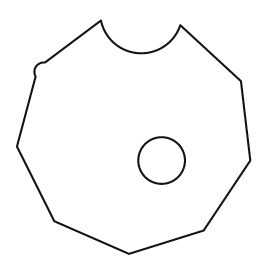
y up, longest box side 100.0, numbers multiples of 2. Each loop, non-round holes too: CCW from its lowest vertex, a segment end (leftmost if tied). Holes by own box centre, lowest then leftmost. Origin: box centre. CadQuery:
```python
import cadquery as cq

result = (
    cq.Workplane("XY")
    .moveTo(-2.0, -50.0)
    .lineTo(30.0, -40.0)
    .lineTo(50.0, -10.0)
    .lineTo(46.0, 24.0)
    .lineTo(20.0, 48.0)
    .threePointArc((2.0, 36.0), (-14.0, 50.0))
    .lineTo(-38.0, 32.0)
    .threePointArc((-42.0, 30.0), (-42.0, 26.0))
    .lineTo(-50.0, -4.0)
    .lineTo(-34.0, -36.0)
    .close()
    .moveTo(12.0, -10.0)
    .circle(10.0)
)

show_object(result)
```